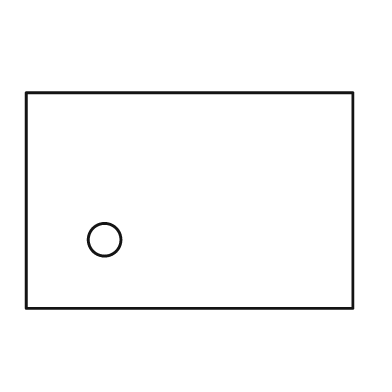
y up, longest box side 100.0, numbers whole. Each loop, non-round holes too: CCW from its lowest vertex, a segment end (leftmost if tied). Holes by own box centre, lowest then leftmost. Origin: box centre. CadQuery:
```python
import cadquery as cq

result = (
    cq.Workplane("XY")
    .moveTo(-50.0, -33.0)
    .lineTo(50.0, -33.0)
    .lineTo(50.0, 33.0)
    .lineTo(-50.0, 33.0)
    .close()
    .moveTo(-26.0, -12.0)
    .circle(5.0)
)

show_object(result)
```